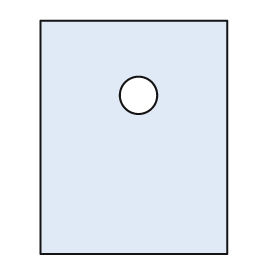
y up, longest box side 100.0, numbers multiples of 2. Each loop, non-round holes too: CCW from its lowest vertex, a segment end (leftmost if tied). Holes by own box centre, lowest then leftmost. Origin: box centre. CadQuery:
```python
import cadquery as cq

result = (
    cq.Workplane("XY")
    .moveTo(-40.0, -50.0)
    .lineTo(40.0, -50.0)
    .lineTo(40.0, 50.0)
    .lineTo(-40.0, 50.0)
    .close()
    .moveTo(2.0, 18.0)
    .circle(8.0)
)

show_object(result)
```